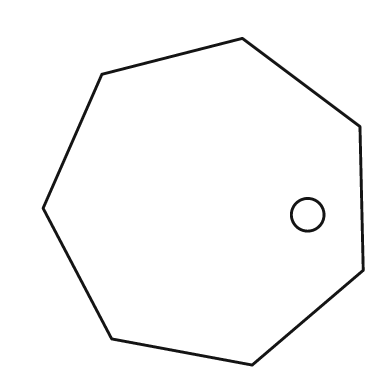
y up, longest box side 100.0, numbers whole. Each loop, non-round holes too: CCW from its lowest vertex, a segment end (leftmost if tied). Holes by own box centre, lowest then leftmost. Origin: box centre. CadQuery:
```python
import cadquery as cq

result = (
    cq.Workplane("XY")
    .moveTo(15.0, -50.0)
    .lineTo(49.0, -21.0)
    .lineTo(48.0, 23.0)
    .lineTo(12.0, 50.0)
    .lineTo(-31.0, 39.0)
    .lineTo(-49.0, -2.0)
    .lineTo(-28.0, -42.0)
    .close()
    .moveTo(32.0, -4.0)
    .circle(5.0)
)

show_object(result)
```